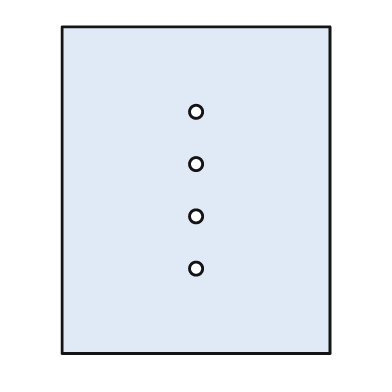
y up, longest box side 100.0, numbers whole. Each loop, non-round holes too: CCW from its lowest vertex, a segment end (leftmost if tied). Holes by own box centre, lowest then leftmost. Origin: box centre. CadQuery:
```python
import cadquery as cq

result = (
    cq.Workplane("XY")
    .moveTo(-41.0, -50.0)
    .lineTo(41.0, -50.0)
    .lineTo(41.0, 50.0)
    .lineTo(-41.0, 50.0)
    .close()
    .moveTo(0.0, -24.0)
    .circle(2.0)
    .moveTo(0.0, -8.0)
    .circle(2.0)
    .moveTo(0.0, 8.0)
    .circle(2.0)
    .moveTo(0.0, 24.0)
    .circle(2.0)
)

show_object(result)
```